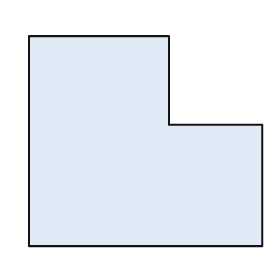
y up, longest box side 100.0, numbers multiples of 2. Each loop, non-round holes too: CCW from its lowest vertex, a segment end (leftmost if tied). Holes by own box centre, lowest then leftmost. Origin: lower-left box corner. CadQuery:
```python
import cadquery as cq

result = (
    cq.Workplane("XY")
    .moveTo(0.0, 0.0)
    .lineTo(100.0, 0.0)
    .lineTo(100.0, 52.0)
    .lineTo(60.0, 52.0)
    .lineTo(60.0, 90.0)
    .lineTo(0.0, 90.0)
    .close()
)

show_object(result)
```